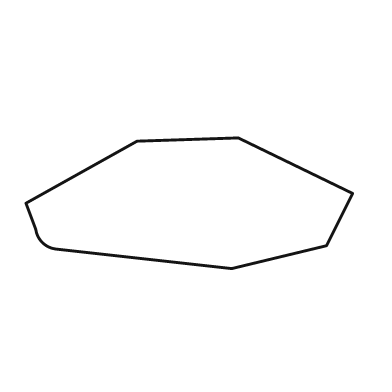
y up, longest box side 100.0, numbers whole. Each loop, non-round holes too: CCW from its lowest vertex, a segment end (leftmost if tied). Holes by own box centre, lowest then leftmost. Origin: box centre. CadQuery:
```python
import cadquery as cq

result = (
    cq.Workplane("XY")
    .moveTo(13.0, -20.0)
    .lineTo(42.0, -13.0)
    .lineTo(50.0, 3.0)
    .lineTo(15.0, 20.0)
    .lineTo(-16.0, 19.0)
    .lineTo(-50.0, 0.0)
    .lineTo(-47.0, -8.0)
    .threePointArc((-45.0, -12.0), (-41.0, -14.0))
    .close()
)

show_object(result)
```